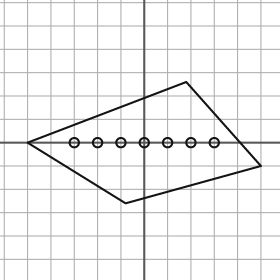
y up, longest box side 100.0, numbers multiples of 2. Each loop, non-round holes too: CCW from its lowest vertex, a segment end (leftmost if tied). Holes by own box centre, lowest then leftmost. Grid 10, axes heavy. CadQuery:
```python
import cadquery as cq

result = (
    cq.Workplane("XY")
    .moveTo(-8.0, -26.0)
    .lineTo(50.0, -10.0)
    .lineTo(18.0, 26.0)
    .lineTo(-50.0, 0.0)
    .close()
    .moveTo(-30.0, 0.0)
    .circle(2.0)
    .moveTo(-20.0, 0.0)
    .circle(2.0)
    .moveTo(-10.0, 0.0)
    .circle(2.0)
    .moveTo(0.0, 0.0)
    .circle(2.0)
    .moveTo(10.0, 0.0)
    .circle(2.0)
    .moveTo(20.0, 0.0)
    .circle(2.0)
    .moveTo(30.0, 0.0)
    .circle(2.0)
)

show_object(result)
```